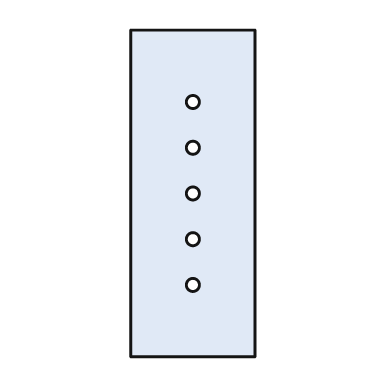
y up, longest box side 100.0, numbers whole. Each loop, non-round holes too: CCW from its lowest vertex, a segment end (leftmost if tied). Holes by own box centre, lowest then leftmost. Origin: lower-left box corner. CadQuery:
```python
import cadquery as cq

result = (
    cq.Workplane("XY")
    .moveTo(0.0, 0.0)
    .lineTo(38.0, 0.0)
    .lineTo(38.0, 100.0)
    .lineTo(0.0, 100.0)
    .close()
    .moveTo(19.0, 22.0)
    .circle(2.0)
    .moveTo(19.0, 36.0)
    .circle(2.0)
    .moveTo(19.0, 50.0)
    .circle(2.0)
    .moveTo(19.0, 64.0)
    .circle(2.0)
    .moveTo(19.0, 78.0)
    .circle(2.0)
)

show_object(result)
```